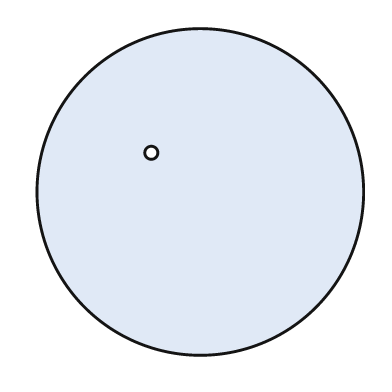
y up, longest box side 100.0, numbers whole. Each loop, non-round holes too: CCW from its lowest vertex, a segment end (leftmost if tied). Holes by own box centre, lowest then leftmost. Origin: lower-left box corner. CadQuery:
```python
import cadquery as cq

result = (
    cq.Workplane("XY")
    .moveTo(50.0, 50.0)
    .circle(50.0)
    .moveTo(35.0, 62.0)
    .circle(2.0)
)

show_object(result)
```